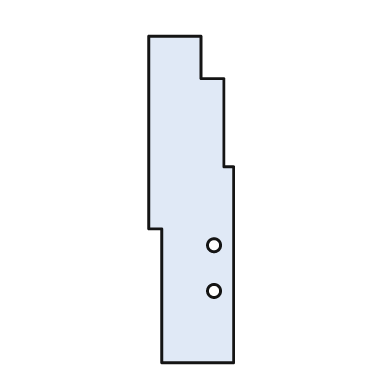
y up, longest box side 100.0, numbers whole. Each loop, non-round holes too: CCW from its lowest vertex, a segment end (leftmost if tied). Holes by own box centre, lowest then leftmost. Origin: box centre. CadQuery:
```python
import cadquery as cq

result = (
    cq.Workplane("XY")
    .moveTo(-9.0, -50.0)
    .lineTo(13.0, -50.0)
    .lineTo(13.0, 10.0)
    .lineTo(10.0, 10.0)
    .lineTo(10.0, 37.0)
    .lineTo(3.0, 37.0)
    .lineTo(3.0, 50.0)
    .lineTo(-13.0, 50.0)
    .lineTo(-13.0, -9.0)
    .lineTo(-9.0, -9.0)
    .close()
    .moveTo(7.0, -28.0)
    .circle(2.0)
    .moveTo(7.0, -14.0)
    .circle(2.0)
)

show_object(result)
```